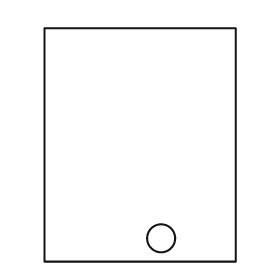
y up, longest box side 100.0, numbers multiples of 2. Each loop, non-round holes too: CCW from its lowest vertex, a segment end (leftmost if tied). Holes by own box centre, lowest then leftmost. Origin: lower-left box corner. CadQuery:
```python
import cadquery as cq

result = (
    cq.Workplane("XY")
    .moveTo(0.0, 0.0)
    .lineTo(82.0, 0.0)
    .lineTo(82.0, 100.0)
    .lineTo(0.0, 100.0)
    .close()
    .moveTo(50.0, 10.0)
    .circle(6.0)
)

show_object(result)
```